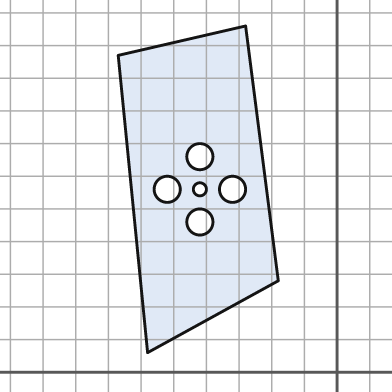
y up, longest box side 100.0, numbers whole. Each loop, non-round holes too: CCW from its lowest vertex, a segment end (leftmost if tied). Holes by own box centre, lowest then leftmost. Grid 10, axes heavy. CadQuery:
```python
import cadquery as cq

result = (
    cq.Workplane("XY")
    .moveTo(-58.0, 6.0)
    .lineTo(-18.0, 28.0)
    .lineTo(-28.0, 106.0)
    .lineTo(-67.0, 97.0)
    .close()
    .moveTo(-42.0, 46.0)
    .circle(4.0)
    .moveTo(-52.0, 56.0)
    .circle(4.0)
    .moveTo(-42.0, 56.0)
    .circle(2.0)
    .moveTo(-32.0, 56.0)
    .circle(4.0)
    .moveTo(-42.0, 66.0)
    .circle(4.0)
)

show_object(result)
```